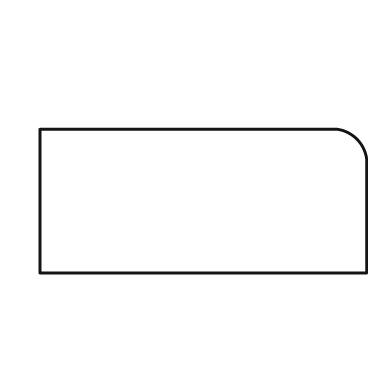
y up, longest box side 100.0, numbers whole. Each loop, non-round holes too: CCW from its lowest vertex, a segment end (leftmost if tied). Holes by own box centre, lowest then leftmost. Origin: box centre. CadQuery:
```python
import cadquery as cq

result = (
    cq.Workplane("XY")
    .moveTo(-50.0, -22.0)
    .lineTo(50.0, -22.0)
    .lineTo(50.0, 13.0)
    .threePointArc((47.0, 19.0), (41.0, 22.0))
    .lineTo(-50.0, 22.0)
    .close()
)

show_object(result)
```